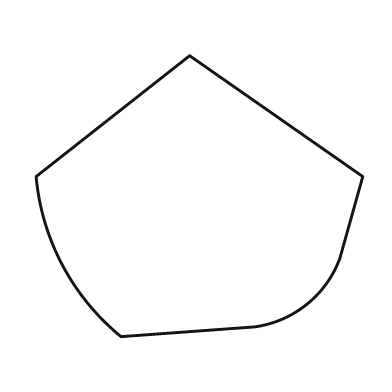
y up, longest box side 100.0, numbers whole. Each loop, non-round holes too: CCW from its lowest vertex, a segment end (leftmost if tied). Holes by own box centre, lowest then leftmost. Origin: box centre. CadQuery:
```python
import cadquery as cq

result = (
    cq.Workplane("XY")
    .moveTo(-24.0, -43.0)
    .lineTo(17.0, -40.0)
    .threePointArc((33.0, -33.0), (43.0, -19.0))
    .lineTo(50.0, 6.0)
    .lineTo(-3.0, 43.0)
    .lineTo(-50.0, 6.0)
    .threePointArc((-42.0, -21.0), (-24.0, -43.0))
    .close()
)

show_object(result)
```